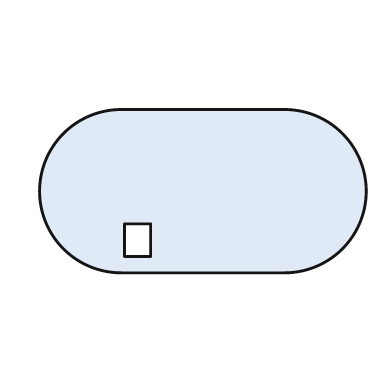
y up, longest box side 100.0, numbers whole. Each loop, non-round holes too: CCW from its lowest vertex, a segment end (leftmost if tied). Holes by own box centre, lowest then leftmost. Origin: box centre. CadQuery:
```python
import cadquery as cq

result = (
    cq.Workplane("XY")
    .moveTo(-25.0, -25.0)
    .lineTo(25.0, -25.0)
    .threePointArc((50.0, 0.0), (25.0, 25.0))
    .lineTo(-25.0, 25.0)
    .threePointArc((-50.0, 0.0), (-25.0, -25.0))
    .close()
    .moveTo(-24.0, -20.0)
    .lineTo(-16.0, -20.0)
    .lineTo(-16.0, -10.0)
    .lineTo(-24.0, -10.0)
    .close()
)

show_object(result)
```